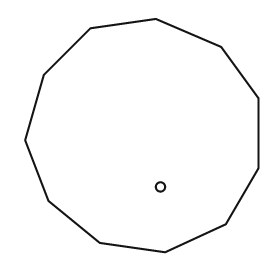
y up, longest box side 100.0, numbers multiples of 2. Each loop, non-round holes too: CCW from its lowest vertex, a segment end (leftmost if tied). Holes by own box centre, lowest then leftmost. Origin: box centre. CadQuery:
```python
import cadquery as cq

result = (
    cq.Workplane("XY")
    .moveTo(10.0, -50.0)
    .lineTo(36.0, -38.0)
    .lineTo(50.0, -14.0)
    .lineTo(50.0, 16.0)
    .lineTo(34.0, 38.0)
    .lineTo(6.0, 50.0)
    .lineTo(-22.0, 46.0)
    .lineTo(-42.0, 26.0)
    .lineTo(-50.0, -2.0)
    .lineTo(-40.0, -28.0)
    .lineTo(-18.0, -46.0)
    .close()
    .moveTo(8.0, -22.0)
    .circle(2.0)
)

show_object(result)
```